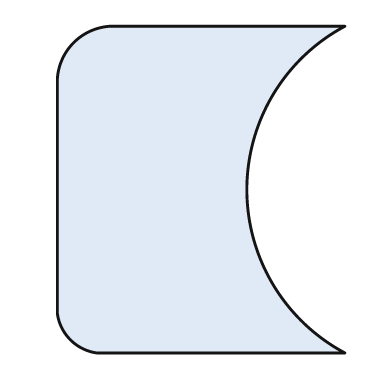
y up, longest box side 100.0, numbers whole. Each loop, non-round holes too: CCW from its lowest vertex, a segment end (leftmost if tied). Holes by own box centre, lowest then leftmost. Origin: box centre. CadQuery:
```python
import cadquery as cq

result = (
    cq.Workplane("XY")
    .moveTo(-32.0, -50.0)
    .lineTo(44.0, -50.0)
    .threePointArc((14.0, 0.0), (44.0, 50.0))
    .lineTo(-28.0, 50.0)
    .threePointArc((-39.0, 45.0), (-44.0, 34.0))
    .lineTo(-44.0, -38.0)
    .threePointArc((-40.0, -46.0), (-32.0, -50.0))
    .close()
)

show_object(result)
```